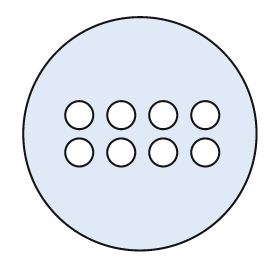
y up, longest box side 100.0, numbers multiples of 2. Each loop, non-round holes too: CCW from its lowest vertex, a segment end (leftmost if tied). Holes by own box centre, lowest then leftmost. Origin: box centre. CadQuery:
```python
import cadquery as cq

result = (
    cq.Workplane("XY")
    .moveTo(0.0, 0.0)
    .circle(50.0)
    .moveTo(-26.0, -8.0)
    .circle(6.0)
    .moveTo(-8.0, -8.0)
    .circle(6.0)
    .moveTo(10.0, -8.0)
    .circle(6.0)
    .moveTo(28.0, -8.0)
    .circle(6.0)
    .moveTo(-26.0, 8.0)
    .circle(6.0)
    .moveTo(-8.0, 8.0)
    .circle(6.0)
    .moveTo(10.0, 8.0)
    .circle(6.0)
    .moveTo(28.0, 8.0)
    .circle(6.0)
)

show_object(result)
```